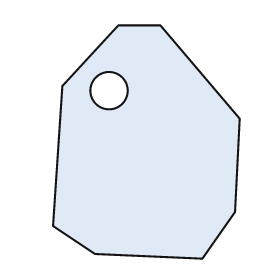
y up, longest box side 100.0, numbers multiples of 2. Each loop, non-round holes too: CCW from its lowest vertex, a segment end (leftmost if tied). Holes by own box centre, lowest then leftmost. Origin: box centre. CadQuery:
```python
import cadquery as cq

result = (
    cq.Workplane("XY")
    .moveTo(24.0, -50.0)
    .lineTo(38.0, -30.0)
    .lineTo(40.0, 10.0)
    .lineTo(6.0, 50.0)
    .lineTo(-12.0, 50.0)
    .lineTo(-36.0, 24.0)
    .lineTo(-40.0, -36.0)
    .lineTo(-22.0, -48.0)
    .close()
    .moveTo(-16.0, 22.0)
    .circle(8.0)
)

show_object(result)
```